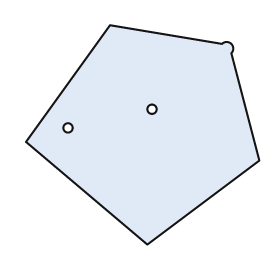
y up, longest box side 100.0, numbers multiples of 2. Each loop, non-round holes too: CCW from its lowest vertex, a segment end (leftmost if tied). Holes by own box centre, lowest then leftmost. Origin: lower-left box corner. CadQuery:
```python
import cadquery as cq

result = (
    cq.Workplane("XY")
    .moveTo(52.0, 0.0)
    .lineTo(100.0, 36.0)
    .lineTo(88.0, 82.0)
    .threePointArc((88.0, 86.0), (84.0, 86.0))
    .lineTo(36.0, 94.0)
    .lineTo(0.0, 44.0)
    .close()
    .moveTo(18.0, 50.0)
    .circle(2.0)
    .moveTo(54.0, 58.0)
    .circle(2.0)
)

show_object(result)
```